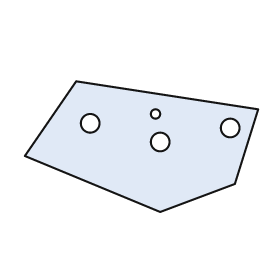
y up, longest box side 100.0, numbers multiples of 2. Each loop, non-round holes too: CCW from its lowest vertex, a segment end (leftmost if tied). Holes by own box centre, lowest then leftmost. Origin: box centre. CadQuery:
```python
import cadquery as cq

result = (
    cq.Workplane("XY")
    .moveTo(8.0, -28.0)
    .lineTo(40.0, -16.0)
    .lineTo(50.0, 16.0)
    .lineTo(-28.0, 28.0)
    .lineTo(-50.0, -4.0)
    .close()
    .moveTo(8.0, 2.0)
    .circle(4.0)
    .moveTo(38.0, 8.0)
    .circle(4.0)
    .moveTo(-22.0, 10.0)
    .circle(4.0)
    .moveTo(6.0, 14.0)
    .circle(2.0)
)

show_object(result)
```